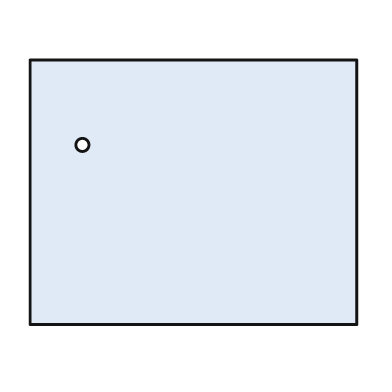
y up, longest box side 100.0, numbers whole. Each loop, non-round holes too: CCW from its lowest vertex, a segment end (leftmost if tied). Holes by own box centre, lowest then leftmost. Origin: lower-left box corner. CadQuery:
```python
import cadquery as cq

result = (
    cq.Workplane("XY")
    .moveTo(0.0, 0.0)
    .lineTo(100.0, 0.0)
    .lineTo(100.0, 81.0)
    .lineTo(0.0, 81.0)
    .close()
    .moveTo(16.0, 55.0)
    .circle(2.0)
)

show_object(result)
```